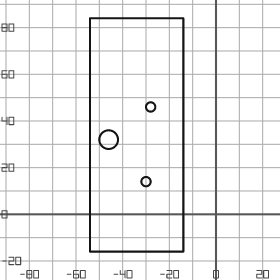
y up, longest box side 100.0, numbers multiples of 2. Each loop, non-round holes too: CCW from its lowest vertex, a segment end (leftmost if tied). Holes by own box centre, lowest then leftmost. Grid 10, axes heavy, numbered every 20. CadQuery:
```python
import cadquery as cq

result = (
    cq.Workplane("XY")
    .moveTo(-54.0, -16.0)
    .lineTo(-14.0, -16.0)
    .lineTo(-14.0, 84.0)
    .lineTo(-54.0, 84.0)
    .close()
    .moveTo(-30.0, 14.0)
    .circle(2.0)
    .moveTo(-46.0, 32.0)
    .circle(4.0)
    .moveTo(-28.0, 46.0)
    .circle(2.0)
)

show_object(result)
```